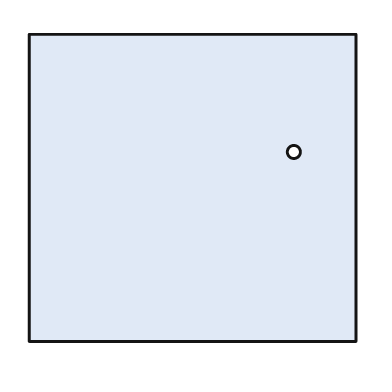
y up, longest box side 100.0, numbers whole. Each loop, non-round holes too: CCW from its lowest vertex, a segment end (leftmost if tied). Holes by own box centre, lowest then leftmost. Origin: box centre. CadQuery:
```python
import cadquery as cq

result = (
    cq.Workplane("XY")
    .moveTo(-50.0, -47.0)
    .lineTo(50.0, -47.0)
    .lineTo(50.0, 47.0)
    .lineTo(-50.0, 47.0)
    .close()
    .moveTo(31.0, 11.0)
    .circle(2.0)
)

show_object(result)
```